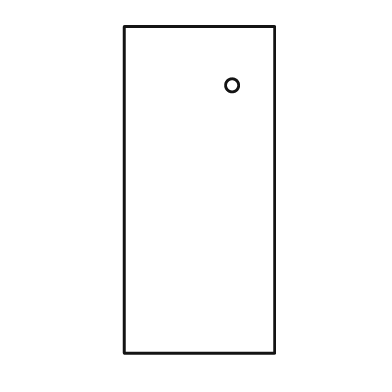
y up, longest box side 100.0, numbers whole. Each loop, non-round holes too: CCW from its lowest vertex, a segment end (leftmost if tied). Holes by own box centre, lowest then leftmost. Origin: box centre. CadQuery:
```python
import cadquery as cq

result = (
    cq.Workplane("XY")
    .moveTo(-23.0, -50.0)
    .lineTo(23.0, -50.0)
    .lineTo(23.0, 50.0)
    .lineTo(-23.0, 50.0)
    .close()
    .moveTo(10.0, 32.0)
    .circle(2.0)
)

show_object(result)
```